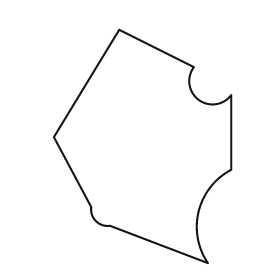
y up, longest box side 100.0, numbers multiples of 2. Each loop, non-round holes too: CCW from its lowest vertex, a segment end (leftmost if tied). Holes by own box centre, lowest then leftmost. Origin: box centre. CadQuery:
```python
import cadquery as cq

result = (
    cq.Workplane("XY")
    .moveTo(28.0, -50.0)
    .threePointArc((24.0, -28.0), (38.0, -10.0))
    .lineTo(38.0, 22.0)
    .threePointArc((24.0, 20.0), (22.0, 34.0))
    .lineTo(-10.0, 50.0)
    .lineTo(-38.0, 4.0)
    .lineTo(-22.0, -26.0)
    .threePointArc((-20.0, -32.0), (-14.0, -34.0))
    .close()
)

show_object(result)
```